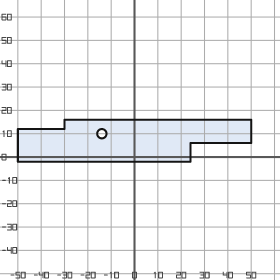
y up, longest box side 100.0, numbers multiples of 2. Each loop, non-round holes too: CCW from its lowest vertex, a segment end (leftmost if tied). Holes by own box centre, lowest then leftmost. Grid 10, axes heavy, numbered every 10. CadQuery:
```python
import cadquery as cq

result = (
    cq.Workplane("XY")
    .moveTo(-50.0, -2.0)
    .lineTo(24.0, -2.0)
    .lineTo(24.0, 6.0)
    .lineTo(50.0, 6.0)
    .lineTo(50.0, 16.0)
    .lineTo(-30.0, 16.0)
    .lineTo(-30.0, 12.0)
    .lineTo(-50.0, 12.0)
    .close()
    .moveTo(-14.0, 10.0)
    .circle(2.0)
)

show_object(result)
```